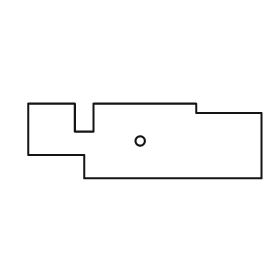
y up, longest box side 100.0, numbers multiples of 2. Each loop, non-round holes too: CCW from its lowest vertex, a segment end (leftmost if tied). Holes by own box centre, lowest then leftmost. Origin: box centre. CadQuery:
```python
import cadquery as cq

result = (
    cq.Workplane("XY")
    .moveTo(-26.0, -16.0)
    .lineTo(50.0, -16.0)
    .lineTo(50.0, 12.0)
    .lineTo(22.0, 12.0)
    .lineTo(22.0, 16.0)
    .lineTo(-22.0, 16.0)
    .lineTo(-22.0, 4.0)
    .lineTo(-30.0, 4.0)
    .lineTo(-30.0, 16.0)
    .lineTo(-50.0, 16.0)
    .lineTo(-50.0, -6.0)
    .lineTo(-26.0, -6.0)
    .close()
    .moveTo(-2.0, 0.0)
    .circle(2.0)
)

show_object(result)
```